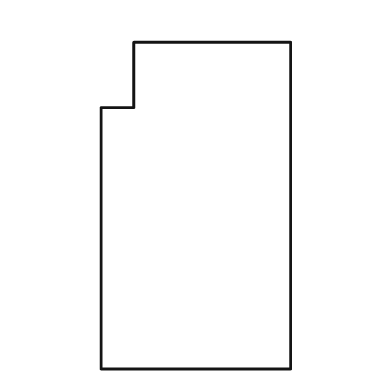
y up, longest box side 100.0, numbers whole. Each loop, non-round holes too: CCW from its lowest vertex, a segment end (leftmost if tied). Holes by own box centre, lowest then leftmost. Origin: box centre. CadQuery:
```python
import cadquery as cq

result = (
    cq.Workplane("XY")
    .moveTo(-29.0, -50.0)
    .lineTo(29.0, -50.0)
    .lineTo(29.0, 50.0)
    .lineTo(-19.0, 50.0)
    .lineTo(-19.0, 30.0)
    .lineTo(-29.0, 30.0)
    .close()
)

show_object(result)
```